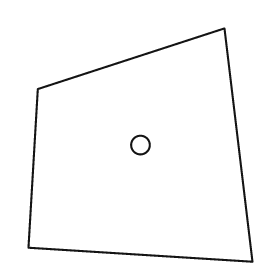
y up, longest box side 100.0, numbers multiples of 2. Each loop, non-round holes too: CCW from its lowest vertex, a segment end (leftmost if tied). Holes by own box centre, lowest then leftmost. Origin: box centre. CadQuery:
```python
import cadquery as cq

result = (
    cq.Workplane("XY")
    .moveTo(48.0, -50.0)
    .lineTo(36.0, 50.0)
    .lineTo(-44.0, 24.0)
    .lineTo(-48.0, -44.0)
    .close()
    .moveTo(0.0, 0.0)
    .circle(4.0)
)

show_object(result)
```